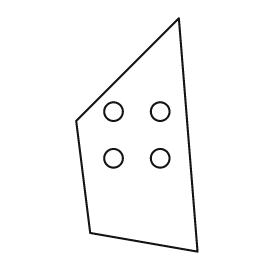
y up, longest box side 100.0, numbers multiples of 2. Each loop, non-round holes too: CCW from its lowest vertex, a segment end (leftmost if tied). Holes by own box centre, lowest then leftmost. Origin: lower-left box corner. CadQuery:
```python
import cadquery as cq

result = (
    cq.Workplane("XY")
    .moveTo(52.0, 0.0)
    .lineTo(44.0, 100.0)
    .lineTo(0.0, 56.0)
    .lineTo(6.0, 8.0)
    .close()
    .moveTo(16.0, 40.0)
    .circle(4.0)
    .moveTo(36.0, 40.0)
    .circle(4.0)
    .moveTo(16.0, 60.0)
    .circle(4.0)
    .moveTo(36.0, 60.0)
    .circle(4.0)
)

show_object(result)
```